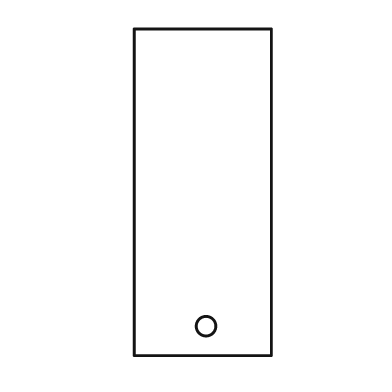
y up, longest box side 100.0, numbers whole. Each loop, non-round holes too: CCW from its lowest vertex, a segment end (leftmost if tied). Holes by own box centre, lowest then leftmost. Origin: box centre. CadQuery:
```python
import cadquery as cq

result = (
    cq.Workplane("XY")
    .moveTo(-21.0, -50.0)
    .lineTo(21.0, -50.0)
    .lineTo(21.0, 50.0)
    .lineTo(-21.0, 50.0)
    .close()
    .moveTo(1.0, -41.0)
    .circle(3.0)
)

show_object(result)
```